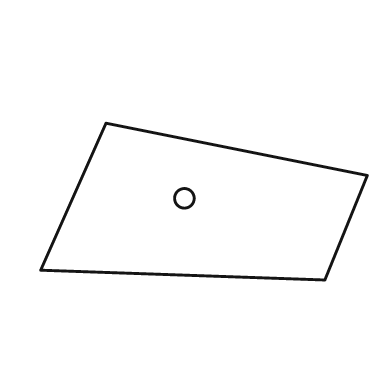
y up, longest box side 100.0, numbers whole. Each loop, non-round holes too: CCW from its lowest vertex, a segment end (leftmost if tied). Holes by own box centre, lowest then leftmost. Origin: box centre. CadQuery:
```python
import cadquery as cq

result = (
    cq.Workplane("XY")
    .moveTo(37.0, -24.0)
    .lineTo(50.0, 8.0)
    .lineTo(-30.0, 24.0)
    .lineTo(-50.0, -21.0)
    .close()
    .moveTo(-6.0, 1.0)
    .circle(3.0)
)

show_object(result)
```